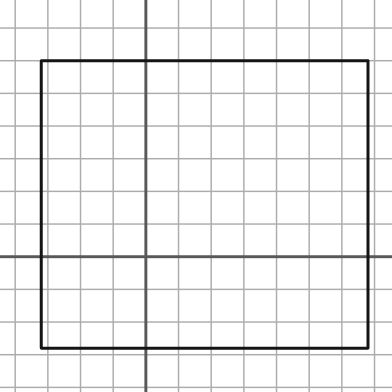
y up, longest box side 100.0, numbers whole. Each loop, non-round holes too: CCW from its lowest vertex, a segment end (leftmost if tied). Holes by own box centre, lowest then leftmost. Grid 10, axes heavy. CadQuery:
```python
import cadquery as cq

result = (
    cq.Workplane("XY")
    .moveTo(-32.0, -28.0)
    .lineTo(68.0, -28.0)
    .lineTo(68.0, 60.0)
    .lineTo(-32.0, 60.0)
    .close()
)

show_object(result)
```